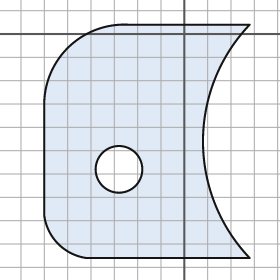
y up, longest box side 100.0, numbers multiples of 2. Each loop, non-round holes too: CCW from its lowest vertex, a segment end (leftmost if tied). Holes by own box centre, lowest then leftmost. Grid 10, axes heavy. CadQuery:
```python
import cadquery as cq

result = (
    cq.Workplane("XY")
    .moveTo(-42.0, -96.0)
    .lineTo(28.0, -96.0)
    .threePointArc((8.0, -46.0), (28.0, 4.0))
    .lineTo(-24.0, 4.0)
    .threePointArc((-50.0, -6.0), (-60.0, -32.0))
    .lineTo(-60.0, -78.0)
    .threePointArc((-54.0, -90.0), (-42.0, -96.0))
    .close()
    .moveTo(-28.0, -58.0)
    .circle(10.0)
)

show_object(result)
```